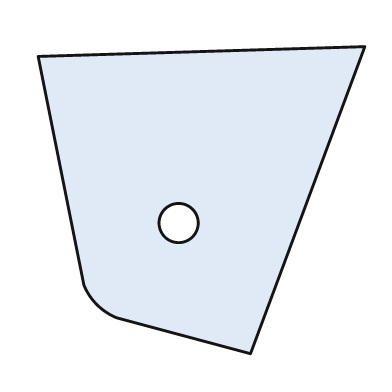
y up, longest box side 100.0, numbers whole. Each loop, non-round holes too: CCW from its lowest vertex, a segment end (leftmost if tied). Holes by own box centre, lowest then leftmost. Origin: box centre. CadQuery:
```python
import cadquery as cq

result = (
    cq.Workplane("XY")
    .moveTo(15.0, -47.0)
    .lineTo(50.0, 47.0)
    .lineTo(-50.0, 44.0)
    .lineTo(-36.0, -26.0)
    .threePointArc((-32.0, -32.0), (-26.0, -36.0))
    .close()
    .moveTo(-7.0, -7.0)
    .circle(6.0)
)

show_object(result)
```